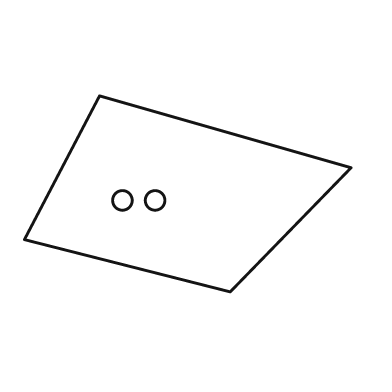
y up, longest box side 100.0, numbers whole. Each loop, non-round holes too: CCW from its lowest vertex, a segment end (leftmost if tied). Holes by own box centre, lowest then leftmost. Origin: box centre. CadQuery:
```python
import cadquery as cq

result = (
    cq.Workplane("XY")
    .moveTo(13.0, -30.0)
    .lineTo(50.0, 8.0)
    .lineTo(-27.0, 30.0)
    .lineTo(-50.0, -14.0)
    .close()
    .moveTo(-20.0, -2.0)
    .circle(3.0)
    .moveTo(-10.0, -2.0)
    .circle(3.0)
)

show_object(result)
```